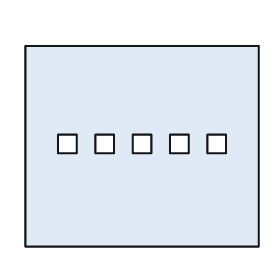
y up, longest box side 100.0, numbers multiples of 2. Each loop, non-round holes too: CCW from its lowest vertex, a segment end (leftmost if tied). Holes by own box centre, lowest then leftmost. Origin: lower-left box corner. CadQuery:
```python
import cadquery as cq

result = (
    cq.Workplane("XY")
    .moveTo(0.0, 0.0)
    .lineTo(100.0, 0.0)
    .lineTo(100.0, 86.0)
    .lineTo(0.0, 86.0)
    .close()
    .moveTo(14.0, 40.0)
    .lineTo(22.0, 40.0)
    .lineTo(22.0, 48.0)
    .lineTo(14.0, 48.0)
    .close()
    .moveTo(30.0, 40.0)
    .lineTo(38.0, 40.0)
    .lineTo(38.0, 48.0)
    .lineTo(30.0, 48.0)
    .close()
    .moveTo(46.0, 40.0)
    .lineTo(54.0, 40.0)
    .lineTo(54.0, 48.0)
    .lineTo(46.0, 48.0)
    .close()
    .moveTo(62.0, 40.0)
    .lineTo(70.0, 40.0)
    .lineTo(70.0, 48.0)
    .lineTo(62.0, 48.0)
    .close()
    .moveTo(78.0, 40.0)
    .lineTo(86.0, 40.0)
    .lineTo(86.0, 48.0)
    .lineTo(78.0, 48.0)
    .close()
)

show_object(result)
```